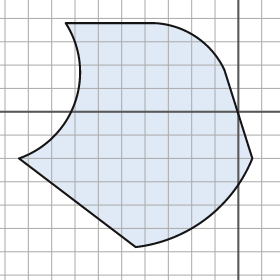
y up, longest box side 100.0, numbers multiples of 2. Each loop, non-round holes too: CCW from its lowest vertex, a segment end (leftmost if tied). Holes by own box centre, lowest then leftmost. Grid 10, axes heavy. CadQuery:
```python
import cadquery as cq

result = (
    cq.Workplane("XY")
    .moveTo(-44.0, -58.0)
    .threePointArc((-14.0, -46.0), (6.0, -20.0))
    .lineTo(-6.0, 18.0)
    .threePointArc((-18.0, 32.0), (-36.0, 38.0))
    .lineTo(-74.0, 38.0)
    .threePointArc((-70.0, 4.0), (-94.0, -20.0))
    .close()
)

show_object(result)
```